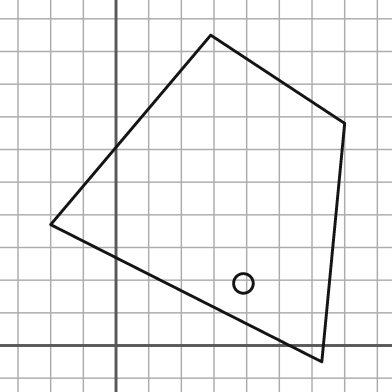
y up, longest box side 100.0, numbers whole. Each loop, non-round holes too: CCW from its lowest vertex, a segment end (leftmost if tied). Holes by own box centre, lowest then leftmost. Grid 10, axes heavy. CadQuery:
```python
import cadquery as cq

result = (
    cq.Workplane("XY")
    .moveTo(63.0, -5.0)
    .lineTo(70.0, 68.0)
    .lineTo(29.0, 95.0)
    .lineTo(-20.0, 37.0)
    .close()
    .moveTo(39.0, 19.0)
    .circle(3.0)
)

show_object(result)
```